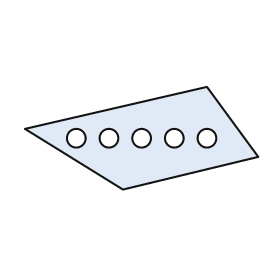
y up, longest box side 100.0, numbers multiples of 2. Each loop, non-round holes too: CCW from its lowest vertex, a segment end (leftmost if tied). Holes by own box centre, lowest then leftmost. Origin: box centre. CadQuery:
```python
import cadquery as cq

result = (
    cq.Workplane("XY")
    .moveTo(-8.0, -22.0)
    .lineTo(50.0, -8.0)
    .lineTo(28.0, 22.0)
    .lineTo(-50.0, 4.0)
    .close()
    .moveTo(-28.0, 0.0)
    .circle(4.0)
    .moveTo(-14.0, 0.0)
    .circle(4.0)
    .moveTo(0.0, 0.0)
    .circle(4.0)
    .moveTo(14.0, 0.0)
    .circle(4.0)
    .moveTo(28.0, 0.0)
    .circle(4.0)
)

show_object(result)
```